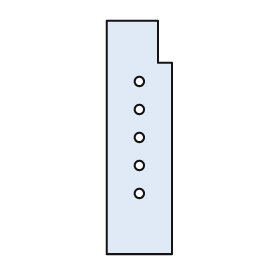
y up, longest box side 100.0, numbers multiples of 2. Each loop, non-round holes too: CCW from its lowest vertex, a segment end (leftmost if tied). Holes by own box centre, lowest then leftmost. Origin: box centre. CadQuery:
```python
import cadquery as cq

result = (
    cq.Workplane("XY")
    .moveTo(-14.0, -50.0)
    .lineTo(14.0, -50.0)
    .lineTo(14.0, 32.0)
    .lineTo(8.0, 32.0)
    .lineTo(8.0, 50.0)
    .lineTo(-14.0, 50.0)
    .close()
    .moveTo(0.0, -24.0)
    .circle(2.0)
    .moveTo(0.0, -12.0)
    .circle(2.0)
    .moveTo(0.0, 0.0)
    .circle(2.0)
    .moveTo(0.0, 12.0)
    .circle(2.0)
    .moveTo(0.0, 24.0)
    .circle(2.0)
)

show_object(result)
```